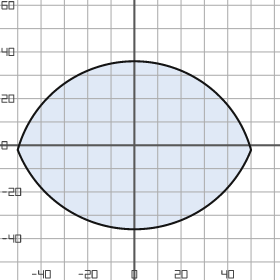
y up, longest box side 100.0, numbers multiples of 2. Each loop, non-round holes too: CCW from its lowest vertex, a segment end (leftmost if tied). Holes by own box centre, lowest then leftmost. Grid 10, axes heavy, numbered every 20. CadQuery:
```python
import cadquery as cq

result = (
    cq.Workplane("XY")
    .moveTo(-50.0, -2.0)
    .threePointArc((0.0, -36.0), (50.0, -2.0))
    .threePointArc((0.0, 36.0), (-50.0, -2.0))
    .close()
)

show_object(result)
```